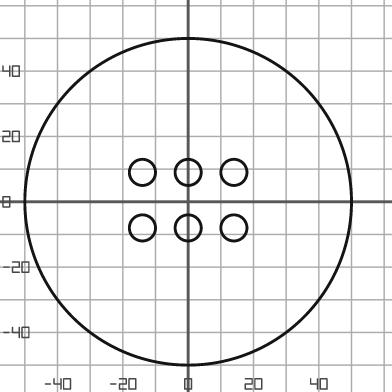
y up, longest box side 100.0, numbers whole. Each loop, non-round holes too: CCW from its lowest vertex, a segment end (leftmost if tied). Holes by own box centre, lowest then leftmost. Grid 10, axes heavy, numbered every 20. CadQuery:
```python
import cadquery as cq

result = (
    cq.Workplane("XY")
    .moveTo(0.0, 0.0)
    .circle(50.0)
    .moveTo(-14.0, -8.0)
    .circle(4.0)
    .moveTo(0.0, -8.0)
    .circle(4.0)
    .moveTo(14.0, -8.0)
    .circle(4.0)
    .moveTo(-14.0, 9.0)
    .circle(4.0)
    .moveTo(0.0, 9.0)
    .circle(4.0)
    .moveTo(14.0, 9.0)
    .circle(4.0)
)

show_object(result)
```